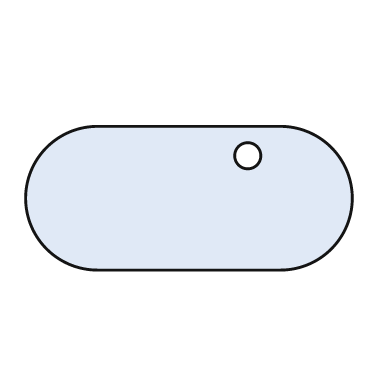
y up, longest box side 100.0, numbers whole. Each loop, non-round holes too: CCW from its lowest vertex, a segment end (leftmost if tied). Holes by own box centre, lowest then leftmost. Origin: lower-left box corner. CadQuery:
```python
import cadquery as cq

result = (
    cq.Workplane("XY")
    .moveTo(22.0, 0.0)
    .lineTo(78.0, 0.0)
    .threePointArc((100.0, 22.0), (78.0, 44.0))
    .lineTo(22.0, 44.0)
    .threePointArc((0.0, 22.0), (22.0, 0.0))
    .close()
    .moveTo(68.0, 35.0)
    .circle(4.0)
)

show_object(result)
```